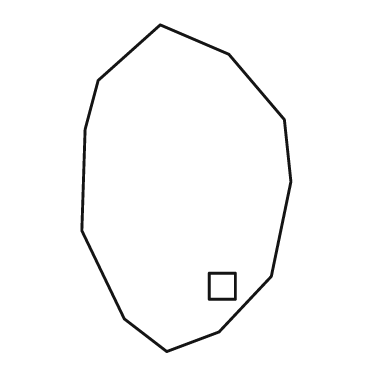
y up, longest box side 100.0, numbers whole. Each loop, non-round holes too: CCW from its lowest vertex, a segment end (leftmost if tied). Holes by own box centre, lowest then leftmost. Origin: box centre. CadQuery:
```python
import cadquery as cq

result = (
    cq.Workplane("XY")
    .moveTo(-6.0, -50.0)
    .lineTo(10.0, -44.0)
    .lineTo(26.0, -27.0)
    .lineTo(32.0, 2.0)
    .lineTo(30.0, 21.0)
    .lineTo(13.0, 41.0)
    .lineTo(-8.0, 50.0)
    .lineTo(-27.0, 33.0)
    .lineTo(-31.0, 18.0)
    .lineTo(-32.0, -13.0)
    .lineTo(-19.0, -40.0)
    .close()
    .moveTo(7.0, -34.0)
    .lineTo(15.0, -34.0)
    .lineTo(15.0, -26.0)
    .lineTo(7.0, -26.0)
    .close()
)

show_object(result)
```